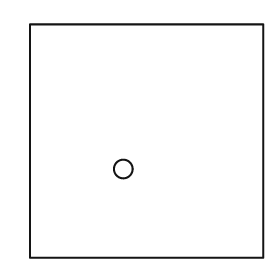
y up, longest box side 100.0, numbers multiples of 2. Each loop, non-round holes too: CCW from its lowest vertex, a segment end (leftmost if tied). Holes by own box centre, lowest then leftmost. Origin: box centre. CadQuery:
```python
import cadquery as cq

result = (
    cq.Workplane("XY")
    .moveTo(-50.0, -50.0)
    .lineTo(50.0, -50.0)
    .lineTo(50.0, 50.0)
    .lineTo(-50.0, 50.0)
    .close()
    .moveTo(-10.0, -12.0)
    .circle(4.0)
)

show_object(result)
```